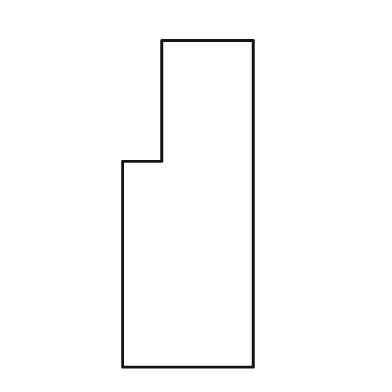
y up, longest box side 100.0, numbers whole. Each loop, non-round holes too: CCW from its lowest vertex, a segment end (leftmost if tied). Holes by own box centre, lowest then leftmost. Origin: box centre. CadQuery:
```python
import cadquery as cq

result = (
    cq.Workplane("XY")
    .moveTo(-20.0, -50.0)
    .lineTo(20.0, -50.0)
    .lineTo(20.0, 50.0)
    .lineTo(-8.0, 50.0)
    .lineTo(-8.0, 13.0)
    .lineTo(-20.0, 13.0)
    .close()
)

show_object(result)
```